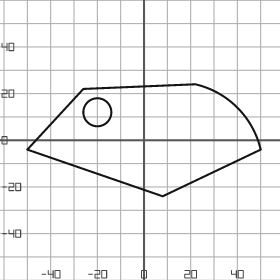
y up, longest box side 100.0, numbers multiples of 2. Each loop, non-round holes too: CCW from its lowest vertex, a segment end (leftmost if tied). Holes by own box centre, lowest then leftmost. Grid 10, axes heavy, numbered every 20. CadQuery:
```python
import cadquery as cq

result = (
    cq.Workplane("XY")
    .moveTo(8.0, -24.0)
    .lineTo(50.0, -4.0)
    .threePointArc((40.0, 14.0), (22.0, 24.0))
    .lineTo(-26.0, 22.0)
    .lineTo(-50.0, -4.0)
    .close()
    .moveTo(-20.0, 12.0)
    .circle(6.0)
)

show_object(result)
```